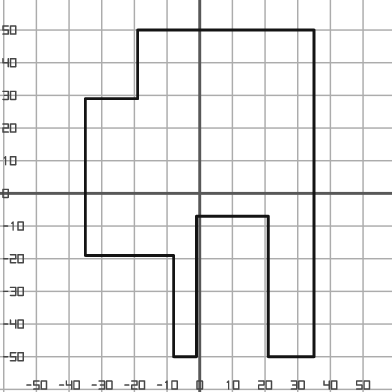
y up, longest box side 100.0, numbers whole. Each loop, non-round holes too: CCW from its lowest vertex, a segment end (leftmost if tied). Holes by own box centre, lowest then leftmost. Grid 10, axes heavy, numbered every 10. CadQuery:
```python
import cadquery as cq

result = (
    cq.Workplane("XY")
    .moveTo(-8.0, -50.0)
    .lineTo(-1.0, -50.0)
    .lineTo(-1.0, -7.0)
    .lineTo(21.0, -7.0)
    .lineTo(21.0, -50.0)
    .lineTo(35.0, -50.0)
    .lineTo(35.0, 50.0)
    .lineTo(-19.0, 50.0)
    .lineTo(-19.0, 29.0)
    .lineTo(-35.0, 29.0)
    .lineTo(-35.0, -19.0)
    .lineTo(-8.0, -19.0)
    .close()
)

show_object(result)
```